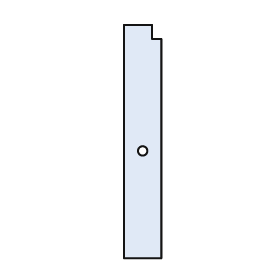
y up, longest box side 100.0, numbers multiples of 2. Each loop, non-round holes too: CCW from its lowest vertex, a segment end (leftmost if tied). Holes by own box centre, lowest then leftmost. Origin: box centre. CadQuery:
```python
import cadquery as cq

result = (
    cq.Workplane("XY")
    .moveTo(-8.0, -50.0)
    .lineTo(8.0, -50.0)
    .lineTo(8.0, 44.0)
    .lineTo(4.0, 44.0)
    .lineTo(4.0, 50.0)
    .lineTo(-8.0, 50.0)
    .close()
    .moveTo(0.0, -4.0)
    .circle(2.0)
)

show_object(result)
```